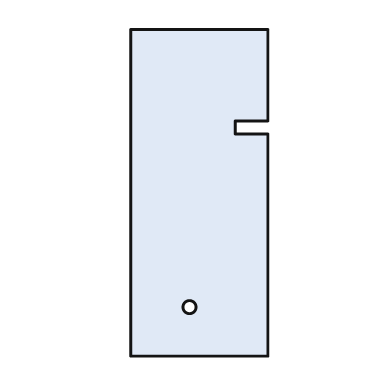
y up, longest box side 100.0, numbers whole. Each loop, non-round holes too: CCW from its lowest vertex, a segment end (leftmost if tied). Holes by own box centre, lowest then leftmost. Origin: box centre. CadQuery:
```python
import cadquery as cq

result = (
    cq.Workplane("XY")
    .moveTo(-21.0, -50.0)
    .lineTo(21.0, -50.0)
    .lineTo(21.0, 18.0)
    .lineTo(11.0, 18.0)
    .lineTo(11.0, 22.0)
    .lineTo(21.0, 22.0)
    .lineTo(21.0, 50.0)
    .lineTo(-21.0, 50.0)
    .close()
    .moveTo(-3.0, -35.0)
    .circle(2.0)
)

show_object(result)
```